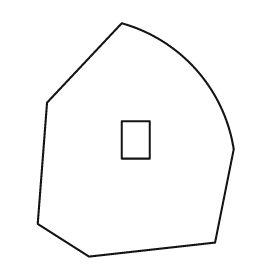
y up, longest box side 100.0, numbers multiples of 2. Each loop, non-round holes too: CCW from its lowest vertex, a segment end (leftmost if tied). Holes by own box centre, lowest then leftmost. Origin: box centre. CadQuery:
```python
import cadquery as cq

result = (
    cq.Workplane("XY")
    .moveTo(-20.0, -50.0)
    .lineTo(34.0, -44.0)
    .lineTo(42.0, -4.0)
    .threePointArc((26.0, 30.0), (-6.0, 50.0))
    .lineTo(-38.0, 16.0)
    .lineTo(-42.0, -36.0)
    .close()
    .moveTo(-6.0, -8.0)
    .lineTo(6.0, -8.0)
    .lineTo(6.0, 8.0)
    .lineTo(-6.0, 8.0)
    .close()
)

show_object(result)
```